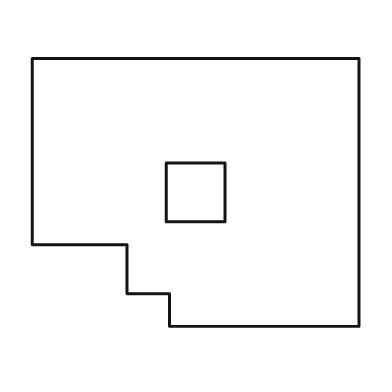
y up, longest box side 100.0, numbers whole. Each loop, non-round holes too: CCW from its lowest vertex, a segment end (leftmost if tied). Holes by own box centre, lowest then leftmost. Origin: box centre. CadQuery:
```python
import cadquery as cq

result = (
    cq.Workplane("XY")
    .moveTo(-8.0, -41.0)
    .lineTo(50.0, -41.0)
    .lineTo(50.0, 41.0)
    .lineTo(-50.0, 41.0)
    .lineTo(-50.0, -16.0)
    .lineTo(-21.0, -16.0)
    .lineTo(-21.0, -31.0)
    .lineTo(-8.0, -31.0)
    .close()
    .moveTo(-9.0, -9.0)
    .lineTo(9.0, -9.0)
    .lineTo(9.0, 9.0)
    .lineTo(-9.0, 9.0)
    .close()
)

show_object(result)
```